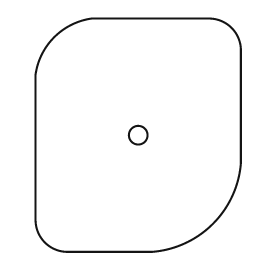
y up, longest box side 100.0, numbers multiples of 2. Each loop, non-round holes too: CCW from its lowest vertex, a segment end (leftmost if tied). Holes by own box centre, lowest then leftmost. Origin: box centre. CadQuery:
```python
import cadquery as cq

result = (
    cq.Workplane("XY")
    .moveTo(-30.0, -50.0)
    .lineTo(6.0, -50.0)
    .threePointArc((32.0, -38.0), (44.0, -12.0))
    .lineTo(44.0, 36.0)
    .threePointArc((40.0, 46.0), (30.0, 50.0))
    .lineTo(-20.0, 50.0)
    .threePointArc((-36.0, 42.0), (-44.0, 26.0))
    .lineTo(-44.0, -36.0)
    .threePointArc((-40.0, -46.0), (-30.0, -50.0))
    .close()
    .moveTo(0.0, 0.0)
    .circle(4.0)
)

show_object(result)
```